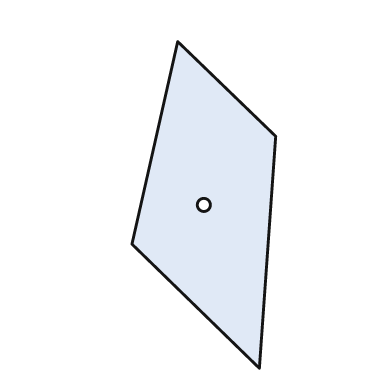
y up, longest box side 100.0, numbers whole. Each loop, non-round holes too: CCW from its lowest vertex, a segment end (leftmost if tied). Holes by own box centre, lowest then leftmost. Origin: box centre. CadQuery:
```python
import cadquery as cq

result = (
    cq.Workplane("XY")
    .moveTo(17.0, -50.0)
    .lineTo(22.0, 21.0)
    .lineTo(-8.0, 50.0)
    .lineTo(-22.0, -12.0)
    .close()
    .moveTo(0.0, 0.0)
    .circle(2.0)
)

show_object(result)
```